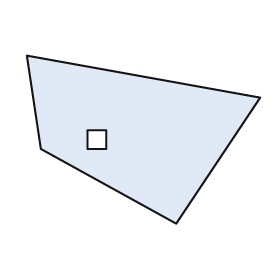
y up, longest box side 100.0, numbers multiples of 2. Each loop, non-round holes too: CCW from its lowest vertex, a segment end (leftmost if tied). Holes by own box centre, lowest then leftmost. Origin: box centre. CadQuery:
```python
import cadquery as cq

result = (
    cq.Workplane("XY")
    .moveTo(14.0, -36.0)
    .lineTo(50.0, 18.0)
    .lineTo(-50.0, 36.0)
    .lineTo(-44.0, -4.0)
    .close()
    .moveTo(-24.0, -4.0)
    .lineTo(-16.0, -4.0)
    .lineTo(-16.0, 4.0)
    .lineTo(-24.0, 4.0)
    .close()
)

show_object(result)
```